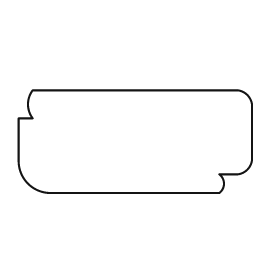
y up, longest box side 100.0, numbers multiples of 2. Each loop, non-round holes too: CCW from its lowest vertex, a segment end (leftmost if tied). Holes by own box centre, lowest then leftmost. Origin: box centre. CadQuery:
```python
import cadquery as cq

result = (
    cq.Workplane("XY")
    .moveTo(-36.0, -22.0)
    .lineTo(36.0, -22.0)
    .threePointArc((38.0, -18.0), (36.0, -14.0))
    .lineTo(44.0, -14.0)
    .threePointArc((48.0, -12.0), (50.0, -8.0))
    .lineTo(50.0, 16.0)
    .threePointArc((48.0, 20.0), (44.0, 22.0))
    .lineTo(-44.0, 22.0)
    .threePointArc((-46.0, 16.0), (-44.0, 10.0))
    .lineTo(-50.0, 10.0)
    .lineTo(-50.0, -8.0)
    .threePointArc((-46.0, -18.0), (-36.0, -22.0))
    .close()
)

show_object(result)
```